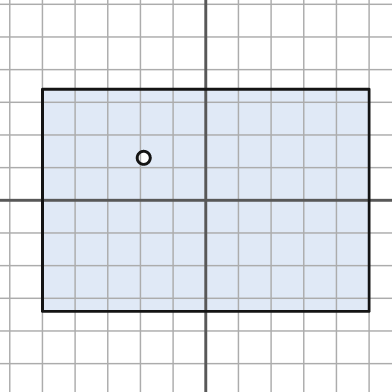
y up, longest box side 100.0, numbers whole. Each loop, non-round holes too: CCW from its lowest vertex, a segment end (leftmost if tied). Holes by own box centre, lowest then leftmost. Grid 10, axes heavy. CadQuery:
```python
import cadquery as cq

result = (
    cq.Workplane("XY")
    .moveTo(-50.0, -34.0)
    .lineTo(50.0, -34.0)
    .lineTo(50.0, 34.0)
    .lineTo(-50.0, 34.0)
    .close()
    .moveTo(-19.0, 13.0)
    .circle(2.0)
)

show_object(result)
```